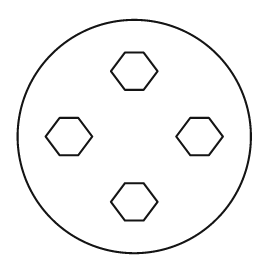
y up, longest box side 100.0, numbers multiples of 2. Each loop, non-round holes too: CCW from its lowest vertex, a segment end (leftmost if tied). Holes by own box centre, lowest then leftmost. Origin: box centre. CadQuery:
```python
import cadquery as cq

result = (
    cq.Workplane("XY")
    .moveTo(0.0, 0.0)
    .circle(50.0)
    .moveTo(-4.0, -36.0)
    .lineTo(4.0, -36.0)
    .lineTo(10.0, -28.0)
    .lineTo(4.0, -20.0)
    .lineTo(-4.0, -20.0)
    .lineTo(-10.0, -28.0)
    .close()
    .moveTo(-32.0, -8.0)
    .lineTo(-24.0, -8.0)
    .lineTo(-18.0, 0.0)
    .lineTo(-24.0, 8.0)
    .lineTo(-32.0, 8.0)
    .lineTo(-38.0, 0.0)
    .close()
    .moveTo(24.0, -8.0)
    .lineTo(32.0, -8.0)
    .lineTo(38.0, 0.0)
    .lineTo(32.0, 8.0)
    .lineTo(24.0, 8.0)
    .lineTo(18.0, 0.0)
    .close()
    .moveTo(-4.0, 20.0)
    .lineTo(4.0, 20.0)
    .lineTo(10.0, 28.0)
    .lineTo(4.0, 36.0)
    .lineTo(-4.0, 36.0)
    .lineTo(-10.0, 28.0)
    .close()
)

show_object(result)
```